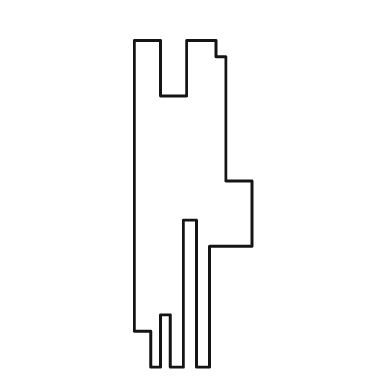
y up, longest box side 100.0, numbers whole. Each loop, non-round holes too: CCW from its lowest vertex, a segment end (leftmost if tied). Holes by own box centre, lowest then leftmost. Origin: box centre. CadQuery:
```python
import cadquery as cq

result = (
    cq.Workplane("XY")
    .moveTo(-13.0, -50.0)
    .lineTo(-10.0, -50.0)
    .lineTo(-10.0, -34.0)
    .lineTo(-7.0, -34.0)
    .lineTo(-7.0, -50.0)
    .lineTo(-3.0, -50.0)
    .lineTo(-3.0, -5.0)
    .lineTo(1.0, -5.0)
    .lineTo(1.0, -50.0)
    .lineTo(5.0, -50.0)
    .lineTo(5.0, -13.0)
    .lineTo(18.0, -13.0)
    .lineTo(18.0, 7.0)
    .lineTo(10.0, 7.0)
    .lineTo(10.0, 45.0)
    .lineTo(7.0, 45.0)
    .lineTo(7.0, 50.0)
    .lineTo(-2.0, 50.0)
    .lineTo(-2.0, 33.0)
    .lineTo(-10.0, 33.0)
    .lineTo(-10.0, 50.0)
    .lineTo(-18.0, 50.0)
    .lineTo(-18.0, -39.0)
    .lineTo(-13.0, -39.0)
    .close()
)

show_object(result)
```